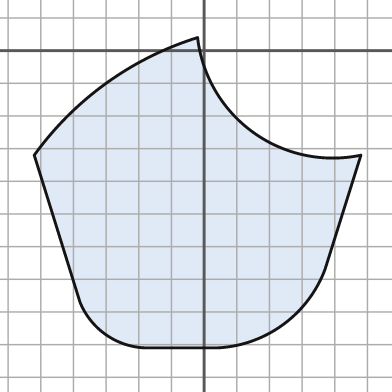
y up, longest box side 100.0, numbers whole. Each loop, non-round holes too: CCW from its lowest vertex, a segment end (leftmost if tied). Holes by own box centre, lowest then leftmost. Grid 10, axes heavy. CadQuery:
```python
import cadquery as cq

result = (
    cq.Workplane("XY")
    .moveTo(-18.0, -91.0)
    .lineTo(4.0, -91.0)
    .threePointArc((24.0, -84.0), (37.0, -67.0))
    .lineTo(48.0, -32.0)
    .threePointArc((15.0, -25.0), (-2.0, 4.0))
    .threePointArc((-30.0, -10.0), (-52.0, -32.0))
    .lineTo(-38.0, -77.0)
    .threePointArc((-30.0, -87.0), (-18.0, -91.0))
    .close()
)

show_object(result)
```